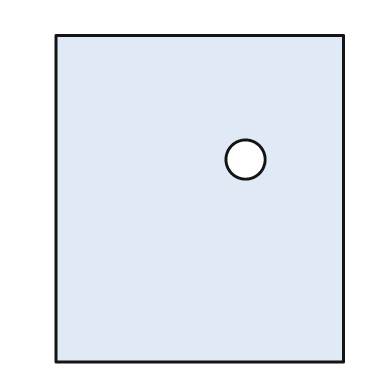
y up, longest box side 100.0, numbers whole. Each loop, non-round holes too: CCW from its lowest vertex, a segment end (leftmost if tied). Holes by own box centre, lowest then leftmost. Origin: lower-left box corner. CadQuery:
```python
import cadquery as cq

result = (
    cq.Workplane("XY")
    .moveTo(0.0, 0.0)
    .lineTo(88.0, 0.0)
    .lineTo(88.0, 100.0)
    .lineTo(0.0, 100.0)
    .close()
    .moveTo(58.0, 62.0)
    .circle(6.0)
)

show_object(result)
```